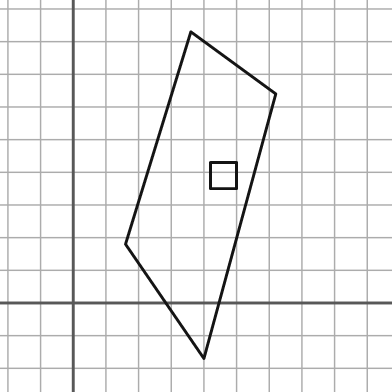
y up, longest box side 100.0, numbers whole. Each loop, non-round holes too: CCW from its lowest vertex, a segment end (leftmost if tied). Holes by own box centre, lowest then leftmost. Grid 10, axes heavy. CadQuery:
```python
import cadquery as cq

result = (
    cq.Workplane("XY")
    .moveTo(40.0, -17.0)
    .lineTo(62.0, 64.0)
    .lineTo(36.0, 83.0)
    .lineTo(16.0, 18.0)
    .close()
    .moveTo(42.0, 35.0)
    .lineTo(50.0, 35.0)
    .lineTo(50.0, 43.0)
    .lineTo(42.0, 43.0)
    .close()
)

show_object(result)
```